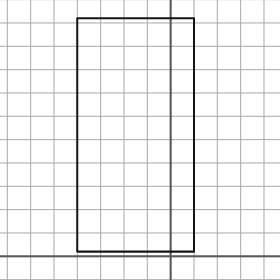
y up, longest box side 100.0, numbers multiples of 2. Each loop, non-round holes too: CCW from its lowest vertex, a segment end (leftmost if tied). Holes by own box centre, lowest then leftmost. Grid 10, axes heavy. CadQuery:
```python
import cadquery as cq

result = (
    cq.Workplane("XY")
    .moveTo(-40.0, 2.0)
    .lineTo(10.0, 2.0)
    .lineTo(10.0, 102.0)
    .lineTo(-40.0, 102.0)
    .close()
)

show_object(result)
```